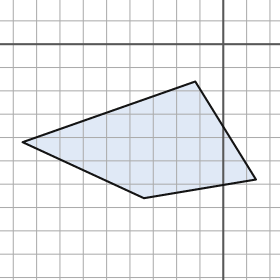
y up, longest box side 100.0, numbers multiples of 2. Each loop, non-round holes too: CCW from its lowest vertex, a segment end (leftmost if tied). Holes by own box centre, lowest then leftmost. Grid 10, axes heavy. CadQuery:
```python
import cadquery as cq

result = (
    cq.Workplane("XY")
    .moveTo(-34.0, -66.0)
    .lineTo(14.0, -58.0)
    .lineTo(-12.0, -16.0)
    .lineTo(-86.0, -42.0)
    .close()
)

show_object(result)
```